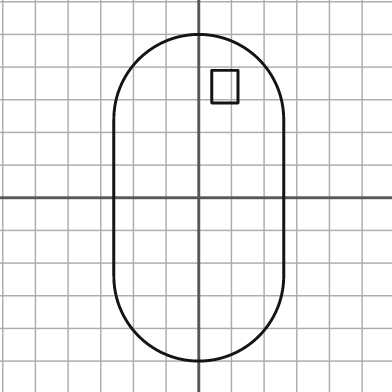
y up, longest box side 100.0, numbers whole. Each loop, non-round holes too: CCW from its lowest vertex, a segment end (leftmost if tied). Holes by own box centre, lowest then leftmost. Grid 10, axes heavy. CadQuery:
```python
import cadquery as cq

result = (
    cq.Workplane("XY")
    .moveTo(-26.0, -24.0)
    .threePointArc((0.0, -50.0), (26.0, -24.0))
    .lineTo(26.0, 24.0)
    .threePointArc((0.0, 50.0), (-26.0, 24.0))
    .close()
    .moveTo(4.0, 29.0)
    .lineTo(12.0, 29.0)
    .lineTo(12.0, 39.0)
    .lineTo(4.0, 39.0)
    .close()
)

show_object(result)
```